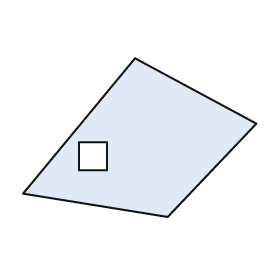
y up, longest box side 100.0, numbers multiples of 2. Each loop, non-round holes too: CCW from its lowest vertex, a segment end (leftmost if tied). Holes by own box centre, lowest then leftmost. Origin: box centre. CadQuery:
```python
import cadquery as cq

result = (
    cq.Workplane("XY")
    .moveTo(12.0, -34.0)
    .lineTo(50.0, 6.0)
    .lineTo(-2.0, 34.0)
    .lineTo(-50.0, -24.0)
    .close()
    .moveTo(-26.0, -14.0)
    .lineTo(-14.0, -14.0)
    .lineTo(-14.0, -2.0)
    .lineTo(-26.0, -2.0)
    .close()
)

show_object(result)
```